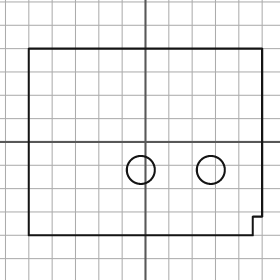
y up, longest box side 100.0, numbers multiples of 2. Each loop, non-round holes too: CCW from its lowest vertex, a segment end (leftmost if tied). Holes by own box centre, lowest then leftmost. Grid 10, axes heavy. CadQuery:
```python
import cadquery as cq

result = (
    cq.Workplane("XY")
    .moveTo(-50.0, -40.0)
    .lineTo(46.0, -40.0)
    .lineTo(46.0, -32.0)
    .lineTo(50.0, -32.0)
    .lineTo(50.0, 40.0)
    .lineTo(-50.0, 40.0)
    .close()
    .moveTo(-2.0, -12.0)
    .circle(6.0)
    .moveTo(28.0, -12.0)
    .circle(6.0)
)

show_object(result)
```